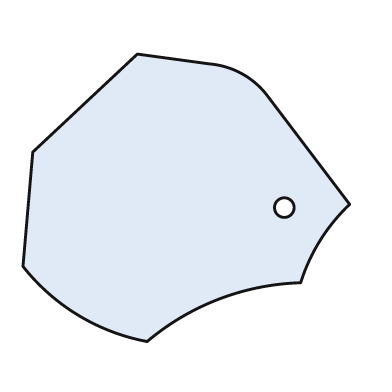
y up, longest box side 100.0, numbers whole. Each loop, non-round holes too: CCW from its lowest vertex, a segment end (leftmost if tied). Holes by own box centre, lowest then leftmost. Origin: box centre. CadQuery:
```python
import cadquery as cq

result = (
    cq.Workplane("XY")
    .moveTo(-12.0, -44.0)
    .threePointArc((10.0, -31.0), (35.0, -26.0))
    .threePointArc((41.0, -13.0), (50.0, -2.0))
    .lineTo(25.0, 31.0)
    .threePointArc((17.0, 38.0), (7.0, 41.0))
    .lineTo(-15.0, 44.0)
    .lineTo(-47.0, 14.0)
    .lineTo(-50.0, -21.0)
    .threePointArc((-33.0, -36.0), (-12.0, -44.0))
    .close()
    .moveTo(30.0, -3.0)
    .circle(3.0)
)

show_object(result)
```